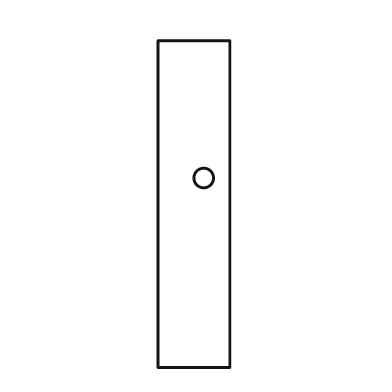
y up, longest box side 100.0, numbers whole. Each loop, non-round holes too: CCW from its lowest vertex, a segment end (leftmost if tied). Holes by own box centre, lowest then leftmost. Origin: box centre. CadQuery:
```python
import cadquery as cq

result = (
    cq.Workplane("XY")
    .moveTo(-11.0, -50.0)
    .lineTo(11.0, -50.0)
    .lineTo(11.0, 50.0)
    .lineTo(-11.0, 50.0)
    .close()
    .moveTo(3.0, 8.0)
    .circle(3.0)
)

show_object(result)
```